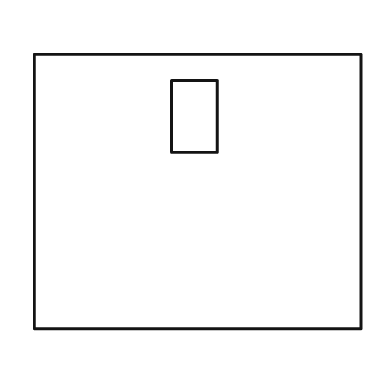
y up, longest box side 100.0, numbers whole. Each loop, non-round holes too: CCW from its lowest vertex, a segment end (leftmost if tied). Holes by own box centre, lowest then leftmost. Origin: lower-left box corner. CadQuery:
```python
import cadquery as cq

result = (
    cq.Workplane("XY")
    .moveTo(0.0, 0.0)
    .lineTo(100.0, 0.0)
    .lineTo(100.0, 84.0)
    .lineTo(0.0, 84.0)
    .close()
    .moveTo(42.0, 54.0)
    .lineTo(56.0, 54.0)
    .lineTo(56.0, 76.0)
    .lineTo(42.0, 76.0)
    .close()
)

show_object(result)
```